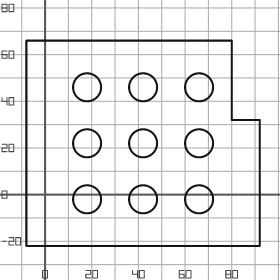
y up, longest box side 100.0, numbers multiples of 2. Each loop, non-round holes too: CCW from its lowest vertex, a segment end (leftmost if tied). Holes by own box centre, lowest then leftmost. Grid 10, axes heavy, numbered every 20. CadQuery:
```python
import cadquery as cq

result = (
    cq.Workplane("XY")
    .moveTo(-8.0, -22.0)
    .lineTo(92.0, -22.0)
    .lineTo(92.0, 32.0)
    .lineTo(80.0, 32.0)
    .lineTo(80.0, 66.0)
    .lineTo(-8.0, 66.0)
    .close()
    .moveTo(18.0, -2.0)
    .circle(6.0)
    .moveTo(42.0, -2.0)
    .circle(6.0)
    .moveTo(66.0, -2.0)
    .circle(6.0)
    .moveTo(18.0, 22.0)
    .circle(6.0)
    .moveTo(42.0, 22.0)
    .circle(6.0)
    .moveTo(66.0, 22.0)
    .circle(6.0)
    .moveTo(18.0, 46.0)
    .circle(6.0)
    .moveTo(42.0, 46.0)
    .circle(6.0)
    .moveTo(66.0, 46.0)
    .circle(6.0)
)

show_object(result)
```